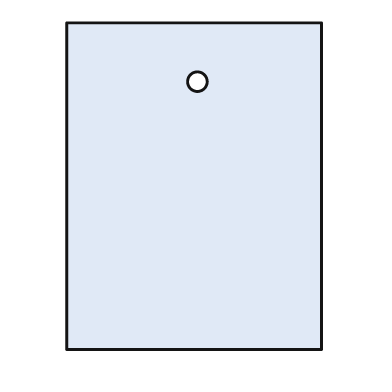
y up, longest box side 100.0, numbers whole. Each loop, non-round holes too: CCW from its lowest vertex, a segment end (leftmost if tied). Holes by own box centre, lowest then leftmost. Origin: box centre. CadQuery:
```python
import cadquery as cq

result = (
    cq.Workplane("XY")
    .moveTo(-39.0, -50.0)
    .lineTo(39.0, -50.0)
    .lineTo(39.0, 50.0)
    .lineTo(-39.0, 50.0)
    .close()
    .moveTo(1.0, 32.0)
    .circle(3.0)
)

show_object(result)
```